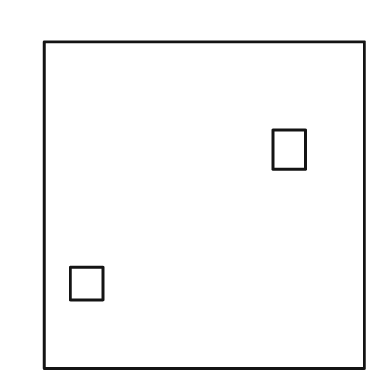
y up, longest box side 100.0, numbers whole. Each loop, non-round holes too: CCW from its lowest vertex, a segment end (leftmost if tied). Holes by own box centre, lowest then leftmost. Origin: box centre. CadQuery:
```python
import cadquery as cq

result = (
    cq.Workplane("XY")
    .moveTo(-49.0, -50.0)
    .lineTo(49.0, -50.0)
    .lineTo(49.0, 50.0)
    .lineTo(-49.0, 50.0)
    .close()
    .moveTo(-41.0, -29.0)
    .lineTo(-31.0, -29.0)
    .lineTo(-31.0, -19.0)
    .lineTo(-41.0, -19.0)
    .close()
    .moveTo(21.0, 11.0)
    .lineTo(31.0, 11.0)
    .lineTo(31.0, 23.0)
    .lineTo(21.0, 23.0)
    .close()
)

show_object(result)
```